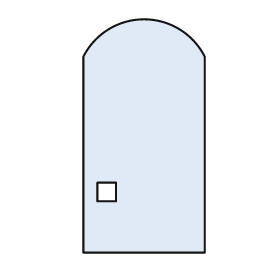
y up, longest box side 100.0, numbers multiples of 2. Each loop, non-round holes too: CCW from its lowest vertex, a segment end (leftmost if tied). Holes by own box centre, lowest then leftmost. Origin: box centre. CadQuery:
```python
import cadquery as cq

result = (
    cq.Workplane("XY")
    .moveTo(-26.0, -50.0)
    .lineTo(26.0, -50.0)
    .lineTo(26.0, 34.0)
    .threePointArc((0.0, 50.0), (-26.0, 34.0))
    .close()
    .moveTo(-20.0, -28.0)
    .lineTo(-12.0, -28.0)
    .lineTo(-12.0, -20.0)
    .lineTo(-20.0, -20.0)
    .close()
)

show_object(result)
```